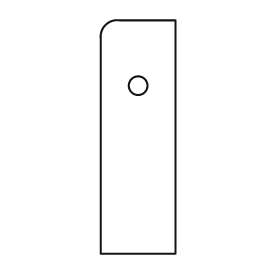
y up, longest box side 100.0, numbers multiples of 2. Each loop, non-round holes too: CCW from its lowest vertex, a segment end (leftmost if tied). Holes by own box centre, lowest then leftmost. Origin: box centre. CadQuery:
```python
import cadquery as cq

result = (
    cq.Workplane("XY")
    .moveTo(-16.0, -50.0)
    .lineTo(16.0, -50.0)
    .lineTo(16.0, 50.0)
    .lineTo(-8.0, 50.0)
    .threePointArc((-14.0, 48.0), (-16.0, 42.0))
    .close()
    .moveTo(0.0, 22.0)
    .circle(4.0)
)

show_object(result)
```